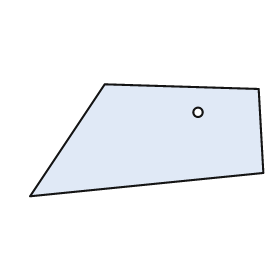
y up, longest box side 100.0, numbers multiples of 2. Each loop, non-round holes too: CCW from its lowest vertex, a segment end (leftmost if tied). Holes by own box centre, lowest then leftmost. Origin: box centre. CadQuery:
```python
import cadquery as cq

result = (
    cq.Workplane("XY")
    .moveTo(-50.0, -24.0)
    .lineTo(50.0, -14.0)
    .lineTo(48.0, 22.0)
    .lineTo(-18.0, 24.0)
    .close()
    .moveTo(22.0, 12.0)
    .circle(2.0)
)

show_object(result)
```